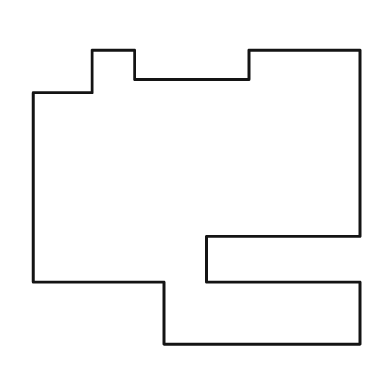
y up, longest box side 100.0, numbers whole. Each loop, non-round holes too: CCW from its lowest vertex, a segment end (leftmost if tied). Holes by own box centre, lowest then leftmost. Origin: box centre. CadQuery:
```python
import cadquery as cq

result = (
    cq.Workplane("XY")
    .moveTo(-10.0, -45.0)
    .lineTo(50.0, -45.0)
    .lineTo(50.0, -26.0)
    .lineTo(3.0, -26.0)
    .lineTo(3.0, -12.0)
    .lineTo(50.0, -12.0)
    .lineTo(50.0, 45.0)
    .lineTo(16.0, 45.0)
    .lineTo(16.0, 36.0)
    .lineTo(-19.0, 36.0)
    .lineTo(-19.0, 45.0)
    .lineTo(-32.0, 45.0)
    .lineTo(-32.0, 32.0)
    .lineTo(-50.0, 32.0)
    .lineTo(-50.0, -26.0)
    .lineTo(-10.0, -26.0)
    .close()
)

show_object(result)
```